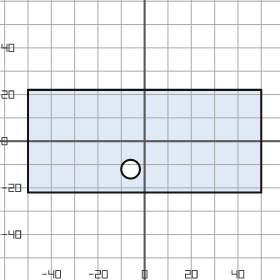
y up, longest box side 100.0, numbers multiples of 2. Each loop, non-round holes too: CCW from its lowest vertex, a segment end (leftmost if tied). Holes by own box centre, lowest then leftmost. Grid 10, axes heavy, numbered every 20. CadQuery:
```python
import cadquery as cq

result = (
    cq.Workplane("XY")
    .moveTo(-50.0, -22.0)
    .lineTo(50.0, -22.0)
    .lineTo(50.0, 22.0)
    .lineTo(-50.0, 22.0)
    .close()
    .moveTo(-6.0, -12.0)
    .circle(4.0)
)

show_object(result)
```